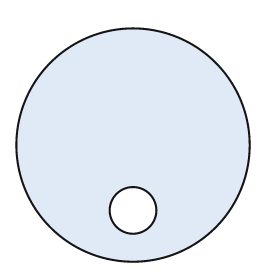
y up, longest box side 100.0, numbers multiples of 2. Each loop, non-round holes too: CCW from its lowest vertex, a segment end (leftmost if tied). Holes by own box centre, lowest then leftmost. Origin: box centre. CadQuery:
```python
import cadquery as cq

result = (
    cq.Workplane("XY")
    .moveTo(0.0, 0.0)
    .circle(50.0)
    .moveTo(0.0, -28.0)
    .circle(10.0)
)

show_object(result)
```